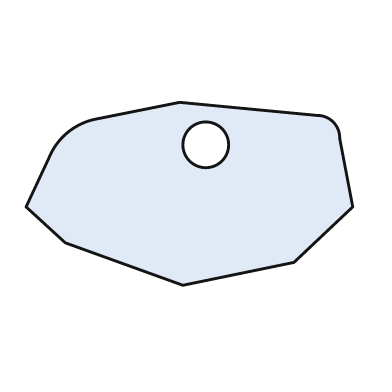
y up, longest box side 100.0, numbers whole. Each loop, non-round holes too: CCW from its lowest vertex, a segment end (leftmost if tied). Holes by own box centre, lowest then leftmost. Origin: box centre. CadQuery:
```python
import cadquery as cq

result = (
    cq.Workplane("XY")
    .moveTo(-2.0, -28.0)
    .lineTo(32.0, -21.0)
    .lineTo(50.0, -4.0)
    .lineTo(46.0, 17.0)
    .threePointArc((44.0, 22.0), (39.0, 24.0))
    .lineTo(-3.0, 28.0)
    .lineTo(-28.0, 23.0)
    .threePointArc((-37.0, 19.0), (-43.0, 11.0))
    .lineTo(-50.0, -4.0)
    .lineTo(-38.0, -15.0)
    .close()
    .moveTo(5.0, 15.0)
    .circle(7.0)
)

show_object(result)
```